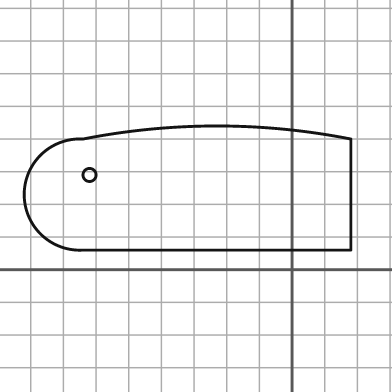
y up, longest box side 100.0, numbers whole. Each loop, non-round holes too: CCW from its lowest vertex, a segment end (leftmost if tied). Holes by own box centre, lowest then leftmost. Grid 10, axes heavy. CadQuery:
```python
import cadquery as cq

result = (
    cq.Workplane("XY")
    .moveTo(-64.0, 6.0)
    .lineTo(18.0, 6.0)
    .lineTo(18.0, 40.0)
    .threePointArc((-23.0, 44.0), (-64.0, 40.0))
    .threePointArc((-82.0, 23.0), (-64.0, 6.0))
    .close()
    .moveTo(-62.0, 29.0)
    .circle(2.0)
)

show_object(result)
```